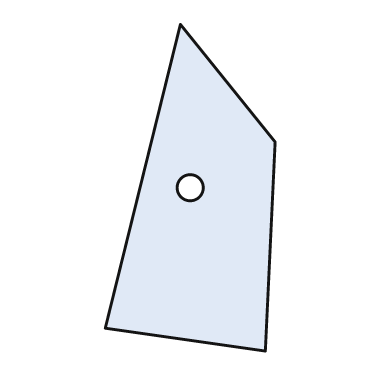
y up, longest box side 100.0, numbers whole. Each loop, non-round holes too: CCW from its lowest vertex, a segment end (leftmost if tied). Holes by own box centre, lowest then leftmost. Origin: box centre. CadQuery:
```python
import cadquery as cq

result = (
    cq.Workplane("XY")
    .moveTo(23.0, -50.0)
    .lineTo(26.0, 14.0)
    .lineTo(-3.0, 50.0)
    .lineTo(-26.0, -43.0)
    .close()
    .moveTo(0.0, 0.0)
    .circle(4.0)
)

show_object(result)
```